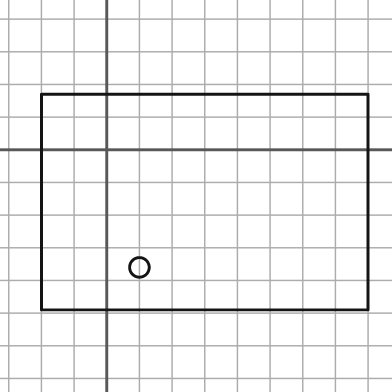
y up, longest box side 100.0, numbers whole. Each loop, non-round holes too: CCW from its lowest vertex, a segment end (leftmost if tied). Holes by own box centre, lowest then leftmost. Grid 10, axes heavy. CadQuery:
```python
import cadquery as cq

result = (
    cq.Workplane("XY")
    .moveTo(-20.0, -49.0)
    .lineTo(80.0, -49.0)
    .lineTo(80.0, 17.0)
    .lineTo(-20.0, 17.0)
    .close()
    .moveTo(10.0, -36.0)
    .circle(3.0)
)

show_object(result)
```